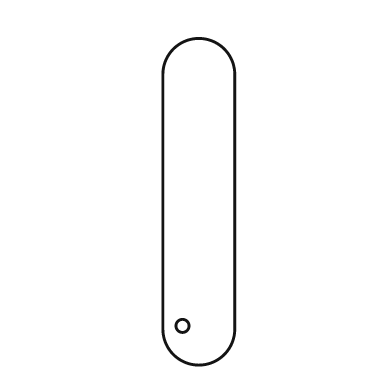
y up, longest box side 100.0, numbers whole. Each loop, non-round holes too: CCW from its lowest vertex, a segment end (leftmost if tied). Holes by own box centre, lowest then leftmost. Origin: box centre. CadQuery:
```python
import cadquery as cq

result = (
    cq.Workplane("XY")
    .moveTo(-11.0, -39.0)
    .threePointArc((0.0, -50.0), (11.0, -39.0))
    .lineTo(11.0, 39.0)
    .threePointArc((0.0, 50.0), (-11.0, 39.0))
    .close()
    .moveTo(-5.0, -38.0)
    .circle(2.0)
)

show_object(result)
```